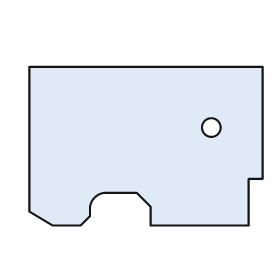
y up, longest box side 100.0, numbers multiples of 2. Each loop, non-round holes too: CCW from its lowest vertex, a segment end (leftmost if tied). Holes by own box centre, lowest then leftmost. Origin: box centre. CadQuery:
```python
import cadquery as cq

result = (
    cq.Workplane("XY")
    .moveTo(-40.0, -34.0)
    .lineTo(-28.0, -34.0)
    .lineTo(-24.0, -30.0)
    .lineTo(-24.0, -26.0)
    .threePointArc((-22.0, -22.0), (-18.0, -20.0))
    .lineTo(-4.0, -20.0)
    .lineTo(2.0, -26.0)
    .lineTo(2.0, -34.0)
    .lineTo(44.0, -34.0)
    .lineTo(44.0, -14.0)
    .lineTo(50.0, -14.0)
    .lineTo(50.0, 34.0)
    .lineTo(-50.0, 34.0)
    .lineTo(-50.0, -28.0)
    .close()
    .moveTo(28.0, 8.0)
    .circle(4.0)
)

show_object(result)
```